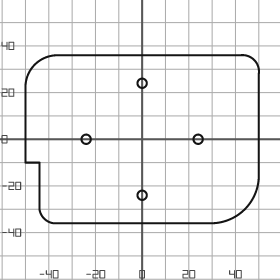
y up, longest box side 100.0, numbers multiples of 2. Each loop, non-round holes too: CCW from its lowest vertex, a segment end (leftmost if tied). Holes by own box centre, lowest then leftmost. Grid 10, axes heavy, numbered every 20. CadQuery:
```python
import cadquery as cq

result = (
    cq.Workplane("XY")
    .moveTo(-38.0, -36.0)
    .lineTo(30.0, -36.0)
    .threePointArc((44.0, -30.0), (50.0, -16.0))
    .lineTo(50.0, 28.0)
    .threePointArc((48.0, 34.0), (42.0, 36.0))
    .lineTo(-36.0, 36.0)
    .threePointArc((-46.0, 32.0), (-50.0, 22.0))
    .lineTo(-50.0, -10.0)
    .lineTo(-44.0, -10.0)
    .lineTo(-44.0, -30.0)
    .threePointArc((-42.0, -34.0), (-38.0, -36.0))
    .close()
    .moveTo(0.0, -24.0)
    .circle(2.0)
    .moveTo(-24.0, 0.0)
    .circle(2.0)
    .moveTo(24.0, 0.0)
    .circle(2.0)
    .moveTo(0.0, 24.0)
    .circle(2.0)
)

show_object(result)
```